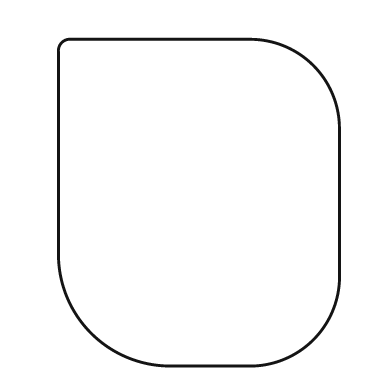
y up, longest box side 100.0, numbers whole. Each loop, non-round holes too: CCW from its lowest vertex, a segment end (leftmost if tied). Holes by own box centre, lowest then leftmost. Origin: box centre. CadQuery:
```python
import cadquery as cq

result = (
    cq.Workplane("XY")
    .moveTo(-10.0, -50.0)
    .lineTo(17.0, -50.0)
    .threePointArc((35.0, -42.0), (43.0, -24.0))
    .lineTo(43.0, 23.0)
    .threePointArc((35.0, 42.0), (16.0, 50.0))
    .lineTo(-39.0, 50.0)
    .threePointArc((-42.0, 49.0), (-43.0, 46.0))
    .lineTo(-43.0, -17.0)
    .threePointArc((-33.0, -40.0), (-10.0, -50.0))
    .close()
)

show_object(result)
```